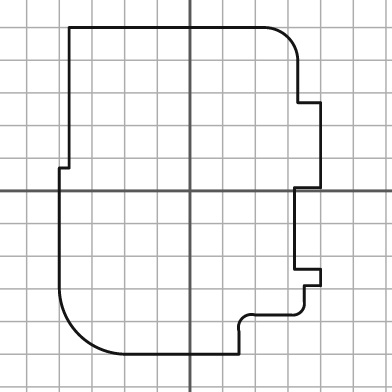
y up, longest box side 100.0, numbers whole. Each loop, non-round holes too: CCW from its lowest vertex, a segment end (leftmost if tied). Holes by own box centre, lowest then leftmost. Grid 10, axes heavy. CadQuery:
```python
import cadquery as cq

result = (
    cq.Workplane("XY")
    .moveTo(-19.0, -50.0)
    .lineTo(15.0, -50.0)
    .lineTo(15.0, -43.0)
    .threePointArc((16.0, -39.0), (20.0, -38.0))
    .lineTo(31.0, -38.0)
    .threePointArc((34.0, -37.0), (35.0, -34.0))
    .lineTo(35.0, -29.0)
    .lineTo(40.0, -29.0)
    .lineTo(40.0, -24.0)
    .lineTo(32.0, -24.0)
    .lineTo(32.0, 1.0)
    .lineTo(40.0, 1.0)
    .lineTo(40.0, 27.0)
    .lineTo(33.0, 27.0)
    .lineTo(33.0, 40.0)
    .threePointArc((30.0, 47.0), (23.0, 50.0))
    .lineTo(-37.0, 50.0)
    .lineTo(-37.0, 7.0)
    .lineTo(-40.0, 7.0)
    .lineTo(-40.0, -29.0)
    .threePointArc((-34.0, -44.0), (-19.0, -50.0))
    .close()
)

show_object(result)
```